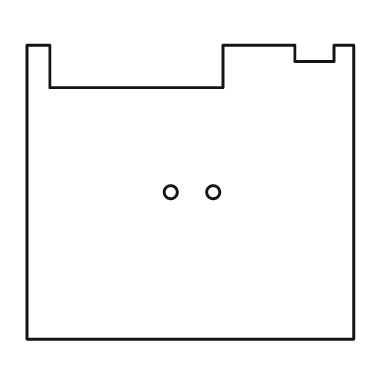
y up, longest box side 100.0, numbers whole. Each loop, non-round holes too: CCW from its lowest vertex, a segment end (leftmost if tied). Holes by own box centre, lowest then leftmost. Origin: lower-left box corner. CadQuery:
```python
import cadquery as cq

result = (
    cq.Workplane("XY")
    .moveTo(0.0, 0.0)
    .lineTo(100.0, 0.0)
    .lineTo(100.0, 90.0)
    .lineTo(94.0, 90.0)
    .lineTo(94.0, 85.0)
    .lineTo(82.0, 85.0)
    .lineTo(82.0, 90.0)
    .lineTo(60.0, 90.0)
    .lineTo(60.0, 77.0)
    .lineTo(7.0, 77.0)
    .lineTo(7.0, 90.0)
    .lineTo(0.0, 90.0)
    .close()
    .moveTo(44.0, 45.0)
    .circle(2.0)
    .moveTo(57.0, 45.0)
    .circle(2.0)
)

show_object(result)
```